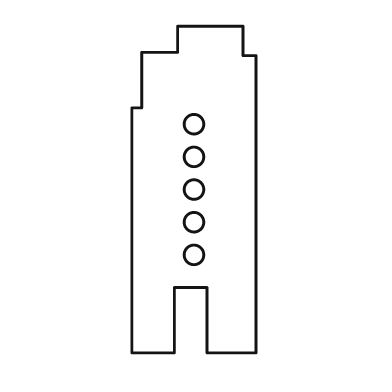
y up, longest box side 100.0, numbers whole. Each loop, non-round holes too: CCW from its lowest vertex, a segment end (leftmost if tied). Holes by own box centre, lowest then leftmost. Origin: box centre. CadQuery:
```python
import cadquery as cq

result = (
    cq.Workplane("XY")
    .moveTo(-19.0, -50.0)
    .lineTo(-6.0, -50.0)
    .lineTo(-6.0, -30.0)
    .lineTo(4.0, -30.0)
    .lineTo(4.0, -50.0)
    .lineTo(19.0, -50.0)
    .lineTo(19.0, 41.0)
    .lineTo(15.0, 41.0)
    .lineTo(15.0, 50.0)
    .lineTo(-5.0, 50.0)
    .lineTo(-5.0, 42.0)
    .lineTo(-16.0, 42.0)
    .lineTo(-16.0, 25.0)
    .lineTo(-19.0, 25.0)
    .close()
    .moveTo(0.0, -20.0)
    .circle(3.0)
    .moveTo(0.0, -10.0)
    .circle(3.0)
    .moveTo(0.0, 0.0)
    .circle(3.0)
    .moveTo(0.0, 10.0)
    .circle(3.0)
    .moveTo(0.0, 20.0)
    .circle(3.0)
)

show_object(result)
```